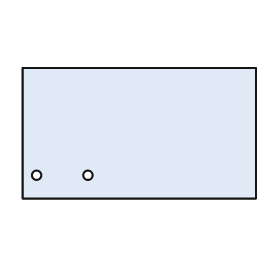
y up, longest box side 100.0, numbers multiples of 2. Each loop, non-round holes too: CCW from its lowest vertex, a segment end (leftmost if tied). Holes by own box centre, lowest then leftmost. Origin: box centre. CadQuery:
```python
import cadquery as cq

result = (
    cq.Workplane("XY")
    .moveTo(-50.0, -28.0)
    .lineTo(50.0, -28.0)
    .lineTo(50.0, 28.0)
    .lineTo(-50.0, 28.0)
    .close()
    .moveTo(-44.0, -18.0)
    .circle(2.0)
    .moveTo(-22.0, -18.0)
    .circle(2.0)
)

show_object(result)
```